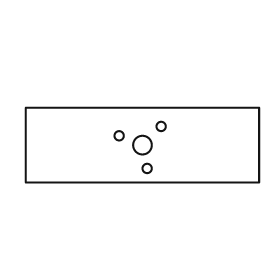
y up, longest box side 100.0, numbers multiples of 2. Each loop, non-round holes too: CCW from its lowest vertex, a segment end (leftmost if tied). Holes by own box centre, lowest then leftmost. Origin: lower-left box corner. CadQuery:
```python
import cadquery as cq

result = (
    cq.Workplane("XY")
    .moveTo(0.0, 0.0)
    .lineTo(100.0, 0.0)
    .lineTo(100.0, 32.0)
    .lineTo(0.0, 32.0)
    .close()
    .moveTo(52.0, 6.0)
    .circle(2.0)
    .moveTo(50.0, 16.0)
    .circle(4.0)
    .moveTo(40.0, 20.0)
    .circle(2.0)
    .moveTo(58.0, 24.0)
    .circle(2.0)
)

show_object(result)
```